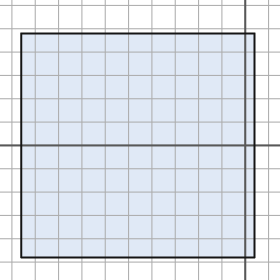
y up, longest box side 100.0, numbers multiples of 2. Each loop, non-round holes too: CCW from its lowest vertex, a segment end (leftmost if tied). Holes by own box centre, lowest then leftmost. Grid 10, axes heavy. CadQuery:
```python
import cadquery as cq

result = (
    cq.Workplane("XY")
    .moveTo(-96.0, -48.0)
    .lineTo(4.0, -48.0)
    .lineTo(4.0, 48.0)
    .lineTo(-96.0, 48.0)
    .close()
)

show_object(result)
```